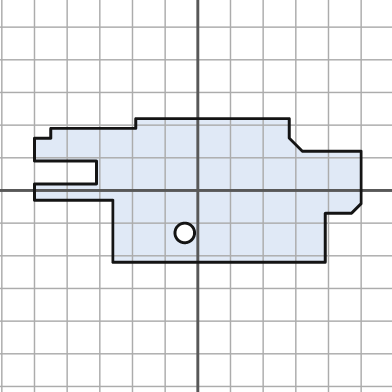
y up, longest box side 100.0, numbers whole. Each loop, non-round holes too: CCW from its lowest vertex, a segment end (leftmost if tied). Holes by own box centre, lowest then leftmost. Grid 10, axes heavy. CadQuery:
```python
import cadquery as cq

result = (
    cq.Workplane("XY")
    .moveTo(-26.0, -22.0)
    .lineTo(39.0, -22.0)
    .lineTo(39.0, -7.0)
    .lineTo(47.0, -7.0)
    .lineTo(50.0, -4.0)
    .lineTo(50.0, 12.0)
    .lineTo(32.0, 12.0)
    .lineTo(28.0, 16.0)
    .lineTo(28.0, 22.0)
    .lineTo(-19.0, 22.0)
    .lineTo(-19.0, 19.0)
    .lineTo(-45.0, 19.0)
    .lineTo(-45.0, 16.0)
    .lineTo(-50.0, 16.0)
    .lineTo(-50.0, 9.0)
    .lineTo(-31.0, 9.0)
    .lineTo(-31.0, 2.0)
    .lineTo(-50.0, 2.0)
    .lineTo(-50.0, -3.0)
    .lineTo(-26.0, -3.0)
    .close()
    .moveTo(-4.0, -13.0)
    .circle(3.0)
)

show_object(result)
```